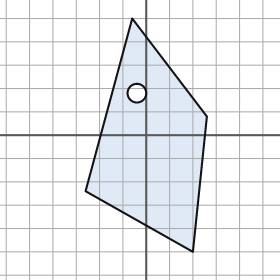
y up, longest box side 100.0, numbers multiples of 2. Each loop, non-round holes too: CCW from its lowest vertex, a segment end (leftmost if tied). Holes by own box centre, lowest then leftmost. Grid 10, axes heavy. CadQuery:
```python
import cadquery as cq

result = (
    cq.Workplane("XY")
    .moveTo(20.0, -50.0)
    .lineTo(26.0, 8.0)
    .lineTo(-6.0, 50.0)
    .lineTo(-26.0, -24.0)
    .close()
    .moveTo(-4.0, 18.0)
    .circle(4.0)
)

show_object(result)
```